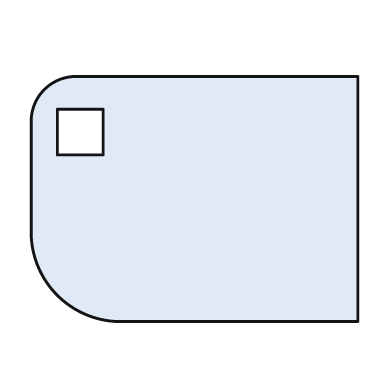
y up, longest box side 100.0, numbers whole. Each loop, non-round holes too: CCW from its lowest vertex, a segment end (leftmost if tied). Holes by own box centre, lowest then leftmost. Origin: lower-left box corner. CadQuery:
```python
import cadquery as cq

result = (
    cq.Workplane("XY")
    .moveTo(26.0, 0.0)
    .lineTo(100.0, 0.0)
    .lineTo(100.0, 75.0)
    .lineTo(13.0, 75.0)
    .threePointArc((4.0, 71.0), (0.0, 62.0))
    .lineTo(0.0, 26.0)
    .threePointArc((8.0, 8.0), (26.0, 0.0))
    .close()
    .moveTo(8.0, 51.0)
    .lineTo(22.0, 51.0)
    .lineTo(22.0, 65.0)
    .lineTo(8.0, 65.0)
    .close()
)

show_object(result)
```